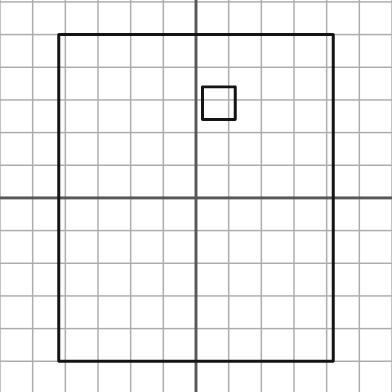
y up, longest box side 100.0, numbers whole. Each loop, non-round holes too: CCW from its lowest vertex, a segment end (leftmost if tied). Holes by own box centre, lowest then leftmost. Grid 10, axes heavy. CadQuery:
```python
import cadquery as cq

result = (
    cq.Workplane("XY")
    .moveTo(-42.0, -50.0)
    .lineTo(42.0, -50.0)
    .lineTo(42.0, 50.0)
    .lineTo(-42.0, 50.0)
    .close()
    .moveTo(2.0, 24.0)
    .lineTo(12.0, 24.0)
    .lineTo(12.0, 34.0)
    .lineTo(2.0, 34.0)
    .close()
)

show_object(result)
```